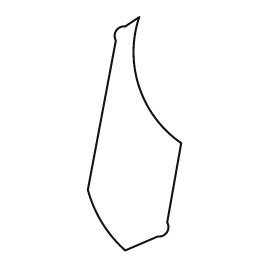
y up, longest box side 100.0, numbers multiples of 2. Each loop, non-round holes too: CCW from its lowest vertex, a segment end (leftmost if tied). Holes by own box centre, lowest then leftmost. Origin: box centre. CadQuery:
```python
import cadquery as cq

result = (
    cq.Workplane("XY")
    .moveTo(-4.0, -50.0)
    .lineTo(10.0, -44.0)
    .threePointArc((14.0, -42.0), (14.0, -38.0))
    .lineTo(20.0, -4.0)
    .threePointArc((2.0, 20.0), (2.0, 50.0))
    .lineTo(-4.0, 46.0)
    .threePointArc((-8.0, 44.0), (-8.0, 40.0))
    .lineTo(-20.0, -24.0)
    .threePointArc((-14.0, -38.0), (-4.0, -50.0))
    .close()
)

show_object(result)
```